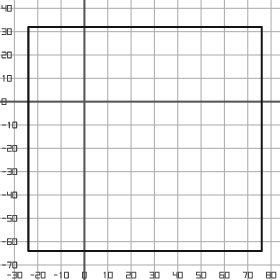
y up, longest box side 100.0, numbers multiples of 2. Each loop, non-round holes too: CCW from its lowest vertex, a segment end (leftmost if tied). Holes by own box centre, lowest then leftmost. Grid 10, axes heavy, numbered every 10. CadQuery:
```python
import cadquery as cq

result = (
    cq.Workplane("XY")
    .moveTo(-24.0, -64.0)
    .lineTo(76.0, -64.0)
    .lineTo(76.0, 32.0)
    .lineTo(-24.0, 32.0)
    .close()
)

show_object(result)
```